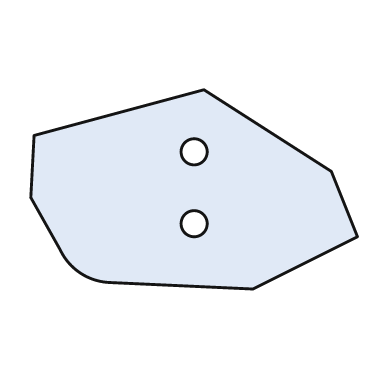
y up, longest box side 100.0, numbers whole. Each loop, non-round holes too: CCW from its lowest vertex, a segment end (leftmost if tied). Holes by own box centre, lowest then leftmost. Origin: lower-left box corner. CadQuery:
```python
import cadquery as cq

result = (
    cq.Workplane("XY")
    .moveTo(68.0, 0.0)
    .lineTo(100.0, 16.0)
    .lineTo(92.0, 36.0)
    .lineTo(53.0, 61.0)
    .lineTo(1.0, 47.0)
    .lineTo(0.0, 28.0)
    .lineTo(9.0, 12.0)
    .threePointArc((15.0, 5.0), (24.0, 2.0))
    .close()
    .moveTo(50.0, 20.0)
    .circle(4.0)
    .moveTo(50.0, 42.0)
    .circle(4.0)
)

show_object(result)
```